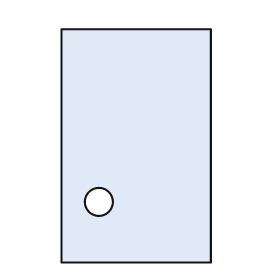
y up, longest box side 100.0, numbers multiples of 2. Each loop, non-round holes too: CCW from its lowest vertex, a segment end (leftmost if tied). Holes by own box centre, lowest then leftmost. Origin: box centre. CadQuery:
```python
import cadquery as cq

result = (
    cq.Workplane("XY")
    .moveTo(-32.0, -50.0)
    .lineTo(32.0, -50.0)
    .lineTo(32.0, 50.0)
    .lineTo(-32.0, 50.0)
    .close()
    .moveTo(-16.0, -24.0)
    .circle(6.0)
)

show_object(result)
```